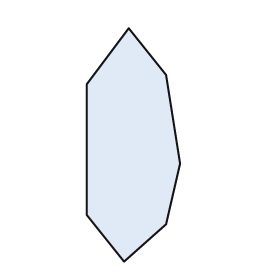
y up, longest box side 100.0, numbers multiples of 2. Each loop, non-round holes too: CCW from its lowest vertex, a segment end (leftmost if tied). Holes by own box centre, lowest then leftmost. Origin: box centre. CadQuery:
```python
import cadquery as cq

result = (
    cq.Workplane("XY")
    .moveTo(-4.0, -50.0)
    .lineTo(14.0, -34.0)
    .lineTo(20.0, -8.0)
    .lineTo(14.0, 30.0)
    .lineTo(-2.0, 50.0)
    .lineTo(-20.0, 26.0)
    .lineTo(-20.0, -30.0)
    .close()
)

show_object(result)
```